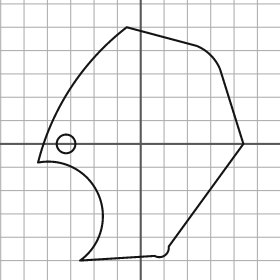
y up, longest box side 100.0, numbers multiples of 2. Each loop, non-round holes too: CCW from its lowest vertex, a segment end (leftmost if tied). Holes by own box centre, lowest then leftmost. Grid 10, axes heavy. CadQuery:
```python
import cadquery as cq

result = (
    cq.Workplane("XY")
    .moveTo(-26.0, -50.0)
    .lineTo(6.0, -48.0)
    .threePointArc((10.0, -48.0), (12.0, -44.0))
    .lineTo(44.0, 0.0)
    .lineTo(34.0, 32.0)
    .threePointArc((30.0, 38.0), (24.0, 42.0))
    .lineTo(-6.0, 50.0)
    .threePointArc((-30.0, 24.0), (-44.0, -8.0))
    .threePointArc((-18.0, -22.0), (-26.0, -50.0))
    .close()
    .moveTo(-32.0, 0.0)
    .circle(4.0)
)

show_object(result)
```